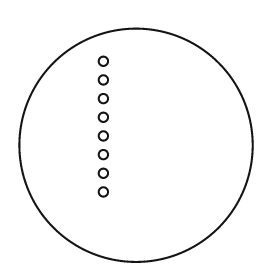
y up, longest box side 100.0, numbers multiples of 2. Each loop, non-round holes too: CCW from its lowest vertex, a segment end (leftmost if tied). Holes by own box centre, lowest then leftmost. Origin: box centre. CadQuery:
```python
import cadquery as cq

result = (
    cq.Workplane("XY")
    .moveTo(0.0, 0.0)
    .circle(50.0)
    .moveTo(-14.0, -20.0)
    .circle(2.0)
    .moveTo(-14.0, -12.0)
    .circle(2.0)
    .moveTo(-14.0, -4.0)
    .circle(2.0)
    .moveTo(-14.0, 4.0)
    .circle(2.0)
    .moveTo(-14.0, 12.0)
    .circle(2.0)
    .moveTo(-14.0, 20.0)
    .circle(2.0)
    .moveTo(-14.0, 28.0)
    .circle(2.0)
    .moveTo(-14.0, 36.0)
    .circle(2.0)
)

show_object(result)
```